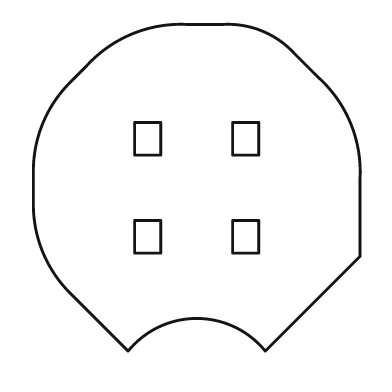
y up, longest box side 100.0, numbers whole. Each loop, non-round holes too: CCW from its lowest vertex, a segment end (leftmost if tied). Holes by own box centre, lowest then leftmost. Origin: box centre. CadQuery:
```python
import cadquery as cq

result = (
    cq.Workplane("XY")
    .moveTo(-21.0, -50.0)
    .threePointArc((0.0, -40.0), (21.0, -50.0))
    .lineTo(50.0, -21.0)
    .lineTo(50.0, 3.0)
    .threePointArc((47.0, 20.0), (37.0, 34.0))
    .lineTo(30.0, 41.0)
    .threePointArc((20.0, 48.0), (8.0, 50.0))
    .lineTo(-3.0, 50.0)
    .threePointArc((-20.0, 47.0), (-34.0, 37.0))
    .lineTo(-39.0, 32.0)
    .threePointArc((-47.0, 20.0), (-50.0, 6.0))
    .lineTo(-50.0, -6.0)
    .threePointArc((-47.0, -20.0), (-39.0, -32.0))
    .close()
    .moveTo(-19.0, -20.0)
    .lineTo(-11.0, -20.0)
    .lineTo(-11.0, -10.0)
    .lineTo(-19.0, -10.0)
    .close()
    .moveTo(11.0, -20.0)
    .lineTo(19.0, -20.0)
    .lineTo(19.0, -10.0)
    .lineTo(11.0, -10.0)
    .close()
    .moveTo(-19.0, 10.0)
    .lineTo(-11.0, 10.0)
    .lineTo(-11.0, 20.0)
    .lineTo(-19.0, 20.0)
    .close()
    .moveTo(11.0, 10.0)
    .lineTo(19.0, 10.0)
    .lineTo(19.0, 20.0)
    .lineTo(11.0, 20.0)
    .close()
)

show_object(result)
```